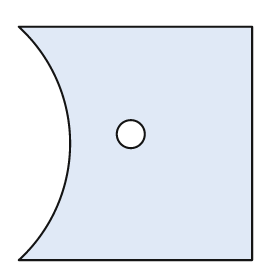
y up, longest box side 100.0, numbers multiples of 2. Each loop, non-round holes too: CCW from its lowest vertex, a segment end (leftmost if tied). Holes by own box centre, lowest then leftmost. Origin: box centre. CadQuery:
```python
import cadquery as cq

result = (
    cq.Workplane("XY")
    .moveTo(-50.0, -50.0)
    .lineTo(50.0, -50.0)
    .lineTo(50.0, 50.0)
    .lineTo(-50.0, 50.0)
    .threePointArc((-28.0, 0.0), (-50.0, -50.0))
    .close()
    .moveTo(-2.0, 4.0)
    .circle(6.0)
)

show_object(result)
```